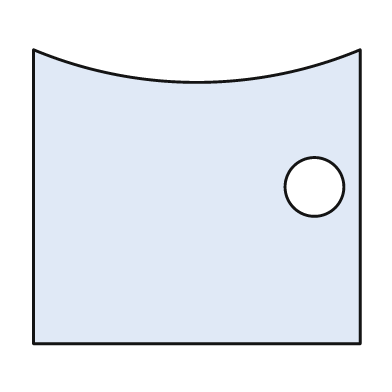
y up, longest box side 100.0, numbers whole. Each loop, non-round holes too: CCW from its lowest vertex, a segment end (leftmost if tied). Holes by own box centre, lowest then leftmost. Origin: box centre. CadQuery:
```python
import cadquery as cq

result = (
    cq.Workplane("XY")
    .moveTo(-50.0, -45.0)
    .lineTo(50.0, -45.0)
    .lineTo(50.0, 45.0)
    .threePointArc((0.0, 35.0), (-50.0, 45.0))
    .close()
    .moveTo(36.0, 3.0)
    .circle(9.0)
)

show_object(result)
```